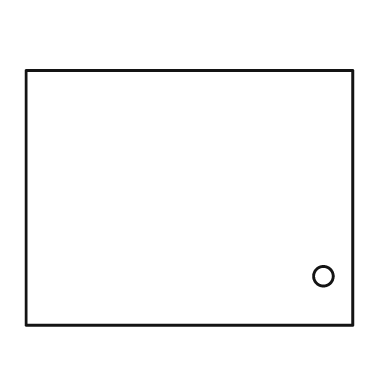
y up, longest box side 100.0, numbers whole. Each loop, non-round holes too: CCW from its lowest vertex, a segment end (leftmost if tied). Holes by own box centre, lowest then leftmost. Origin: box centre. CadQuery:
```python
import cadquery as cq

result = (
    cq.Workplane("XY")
    .moveTo(-50.0, -39.0)
    .lineTo(50.0, -39.0)
    .lineTo(50.0, 39.0)
    .lineTo(-50.0, 39.0)
    .close()
    .moveTo(41.0, -24.0)
    .circle(3.0)
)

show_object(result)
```